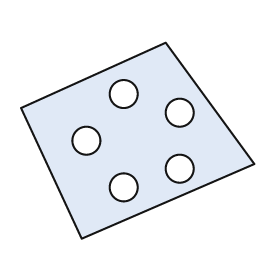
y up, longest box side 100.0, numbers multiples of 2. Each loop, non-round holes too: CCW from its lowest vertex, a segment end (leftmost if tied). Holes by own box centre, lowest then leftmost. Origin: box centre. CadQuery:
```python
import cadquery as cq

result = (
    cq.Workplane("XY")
    .moveTo(-24.0, -42.0)
    .lineTo(50.0, -10.0)
    .lineTo(12.0, 42.0)
    .lineTo(-50.0, 14.0)
    .close()
    .moveTo(-6.0, -20.0)
    .circle(6.0)
    .moveTo(18.0, -12.0)
    .circle(6.0)
    .moveTo(-22.0, 0.0)
    .circle(6.0)
    .moveTo(18.0, 12.0)
    .circle(6.0)
    .moveTo(-6.0, 20.0)
    .circle(6.0)
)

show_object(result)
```